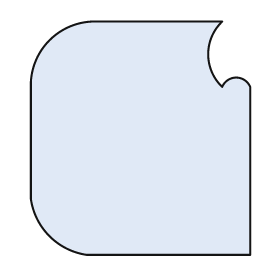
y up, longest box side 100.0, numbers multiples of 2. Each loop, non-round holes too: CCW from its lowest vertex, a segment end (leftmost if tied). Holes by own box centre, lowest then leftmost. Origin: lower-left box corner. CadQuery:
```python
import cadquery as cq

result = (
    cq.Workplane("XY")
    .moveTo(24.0, 0.0)
    .lineTo(94.0, 0.0)
    .lineTo(94.0, 72.0)
    .threePointArc((88.0, 76.0), (82.0, 72.0))
    .threePointArc((76.0, 86.0), (82.0, 100.0))
    .lineTo(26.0, 100.0)
    .threePointArc((8.0, 92.0), (0.0, 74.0))
    .lineTo(0.0, 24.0)
    .threePointArc((8.0, 8.0), (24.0, 0.0))
    .close()
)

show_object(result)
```